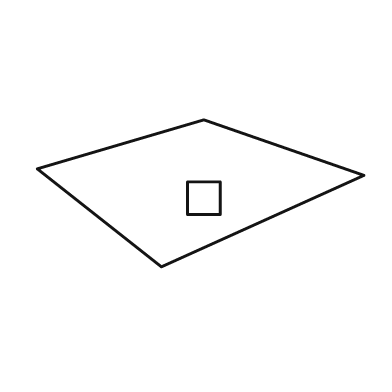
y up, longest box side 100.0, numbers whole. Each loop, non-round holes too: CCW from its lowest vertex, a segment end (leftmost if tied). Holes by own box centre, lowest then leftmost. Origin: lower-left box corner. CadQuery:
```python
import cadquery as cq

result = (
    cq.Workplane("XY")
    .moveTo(38.0, 0.0)
    .lineTo(100.0, 28.0)
    .lineTo(51.0, 45.0)
    .lineTo(0.0, 30.0)
    .close()
    .moveTo(46.0, 16.0)
    .lineTo(56.0, 16.0)
    .lineTo(56.0, 26.0)
    .lineTo(46.0, 26.0)
    .close()
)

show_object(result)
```